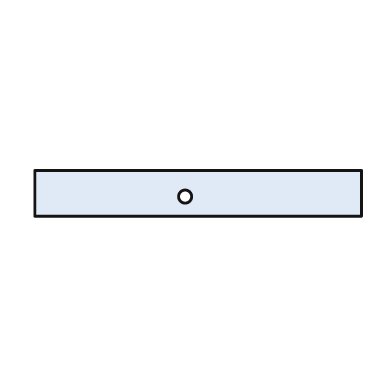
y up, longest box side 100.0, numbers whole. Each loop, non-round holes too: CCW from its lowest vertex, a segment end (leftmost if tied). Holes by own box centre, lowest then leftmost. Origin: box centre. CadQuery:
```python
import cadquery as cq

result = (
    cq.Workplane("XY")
    .moveTo(-50.0, -7.0)
    .lineTo(50.0, -7.0)
    .lineTo(50.0, 7.0)
    .lineTo(-50.0, 7.0)
    .close()
    .moveTo(-4.0, -1.0)
    .circle(2.0)
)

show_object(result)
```